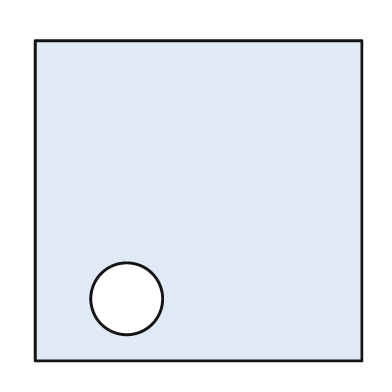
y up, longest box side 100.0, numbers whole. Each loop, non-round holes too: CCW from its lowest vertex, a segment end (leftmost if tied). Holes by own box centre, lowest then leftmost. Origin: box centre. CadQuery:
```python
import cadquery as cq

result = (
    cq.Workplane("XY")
    .moveTo(-50.0, -49.0)
    .lineTo(50.0, -49.0)
    .lineTo(50.0, 49.0)
    .lineTo(-50.0, 49.0)
    .close()
    .moveTo(-22.0, -30.0)
    .circle(11.0)
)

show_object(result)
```